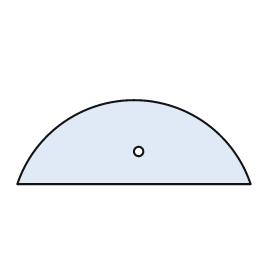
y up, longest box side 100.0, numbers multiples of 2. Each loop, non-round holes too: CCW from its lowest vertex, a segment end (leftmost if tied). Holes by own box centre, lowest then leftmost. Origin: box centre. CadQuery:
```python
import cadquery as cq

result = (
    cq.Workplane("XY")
    .moveTo(-50.0, -18.0)
    .lineTo(50.0, -18.0)
    .threePointArc((0.0, 18.0), (-50.0, -18.0))
    .close()
    .moveTo(2.0, -4.0)
    .circle(2.0)
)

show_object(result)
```